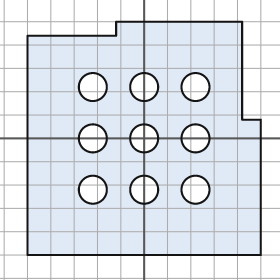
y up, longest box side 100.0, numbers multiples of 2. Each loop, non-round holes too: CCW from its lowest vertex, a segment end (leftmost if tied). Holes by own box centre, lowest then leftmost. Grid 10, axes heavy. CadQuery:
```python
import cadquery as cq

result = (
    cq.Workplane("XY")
    .moveTo(-50.0, -50.0)
    .lineTo(50.0, -50.0)
    .lineTo(50.0, 8.0)
    .lineTo(42.0, 8.0)
    .lineTo(42.0, 50.0)
    .lineTo(-12.0, 50.0)
    .lineTo(-12.0, 44.0)
    .lineTo(-50.0, 44.0)
    .close()
    .moveTo(-22.0, -22.0)
    .circle(6.0)
    .moveTo(0.0, -22.0)
    .circle(6.0)
    .moveTo(22.0, -22.0)
    .circle(6.0)
    .moveTo(-22.0, 0.0)
    .circle(6.0)
    .moveTo(0.0, 0.0)
    .circle(6.0)
    .moveTo(22.0, 0.0)
    .circle(6.0)
    .moveTo(-22.0, 22.0)
    .circle(6.0)
    .moveTo(0.0, 22.0)
    .circle(6.0)
    .moveTo(22.0, 22.0)
    .circle(6.0)
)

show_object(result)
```